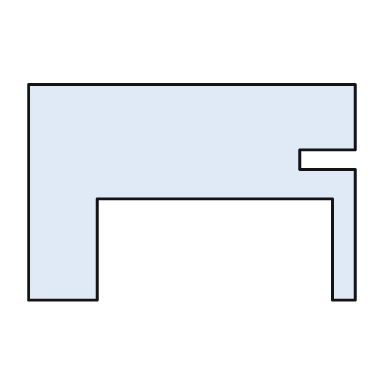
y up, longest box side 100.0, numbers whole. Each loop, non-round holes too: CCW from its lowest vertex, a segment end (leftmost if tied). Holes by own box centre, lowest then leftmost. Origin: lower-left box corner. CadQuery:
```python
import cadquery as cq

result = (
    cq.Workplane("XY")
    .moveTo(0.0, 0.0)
    .lineTo(21.0, 0.0)
    .lineTo(21.0, 31.0)
    .lineTo(93.0, 31.0)
    .lineTo(93.0, 0.0)
    .lineTo(100.0, 0.0)
    .lineTo(100.0, 40.0)
    .lineTo(83.0, 40.0)
    .lineTo(83.0, 46.0)
    .lineTo(100.0, 46.0)
    .lineTo(100.0, 66.0)
    .lineTo(0.0, 66.0)
    .close()
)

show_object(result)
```